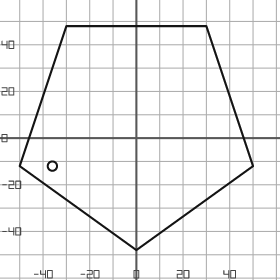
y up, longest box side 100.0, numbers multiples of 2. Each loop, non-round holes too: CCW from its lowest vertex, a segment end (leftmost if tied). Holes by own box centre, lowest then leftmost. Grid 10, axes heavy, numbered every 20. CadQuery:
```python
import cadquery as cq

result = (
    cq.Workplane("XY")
    .moveTo(0.0, -48.0)
    .lineTo(50.0, -12.0)
    .lineTo(30.0, 48.0)
    .lineTo(-30.0, 48.0)
    .lineTo(-50.0, -12.0)
    .close()
    .moveTo(-36.0, -12.0)
    .circle(2.0)
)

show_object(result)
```